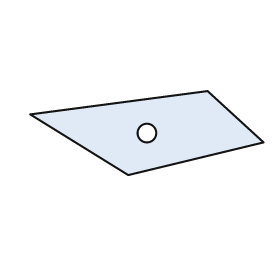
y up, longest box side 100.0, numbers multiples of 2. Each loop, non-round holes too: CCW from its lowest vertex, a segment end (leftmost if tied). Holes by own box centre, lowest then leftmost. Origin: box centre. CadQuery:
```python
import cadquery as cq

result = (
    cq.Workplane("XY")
    .moveTo(-8.0, -18.0)
    .lineTo(50.0, -4.0)
    .lineTo(26.0, 18.0)
    .lineTo(-50.0, 8.0)
    .close()
    .moveTo(0.0, 0.0)
    .circle(4.0)
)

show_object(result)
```